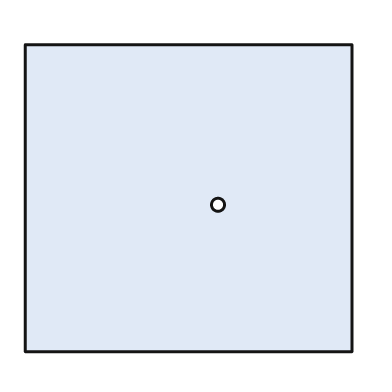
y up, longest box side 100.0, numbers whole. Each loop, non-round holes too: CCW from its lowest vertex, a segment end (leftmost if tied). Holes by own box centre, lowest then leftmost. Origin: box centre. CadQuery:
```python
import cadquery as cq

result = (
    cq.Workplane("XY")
    .moveTo(-50.0, -47.0)
    .lineTo(50.0, -47.0)
    .lineTo(50.0, 47.0)
    .lineTo(-50.0, 47.0)
    .close()
    .moveTo(9.0, -2.0)
    .circle(2.0)
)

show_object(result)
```